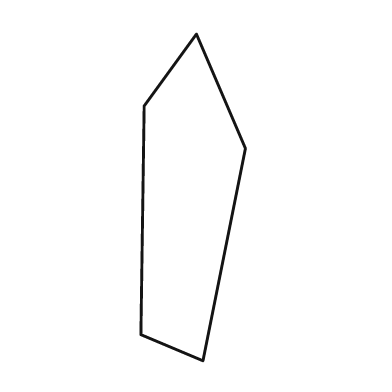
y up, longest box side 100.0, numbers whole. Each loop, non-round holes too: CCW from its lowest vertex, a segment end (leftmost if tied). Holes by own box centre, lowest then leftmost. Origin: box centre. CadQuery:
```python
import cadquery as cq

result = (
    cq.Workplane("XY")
    .moveTo(3.0, -50.0)
    .lineTo(16.0, 15.0)
    .lineTo(1.0, 50.0)
    .lineTo(-15.0, 28.0)
    .lineTo(-16.0, -42.0)
    .close()
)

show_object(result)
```